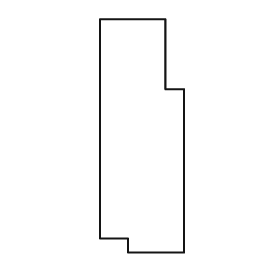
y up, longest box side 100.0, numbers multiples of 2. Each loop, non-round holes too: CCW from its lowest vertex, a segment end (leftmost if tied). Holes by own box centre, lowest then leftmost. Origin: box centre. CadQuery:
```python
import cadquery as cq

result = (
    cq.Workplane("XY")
    .moveTo(-6.0, -50.0)
    .lineTo(18.0, -50.0)
    .lineTo(18.0, 20.0)
    .lineTo(10.0, 20.0)
    .lineTo(10.0, 50.0)
    .lineTo(-18.0, 50.0)
    .lineTo(-18.0, -44.0)
    .lineTo(-6.0, -44.0)
    .close()
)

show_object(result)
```